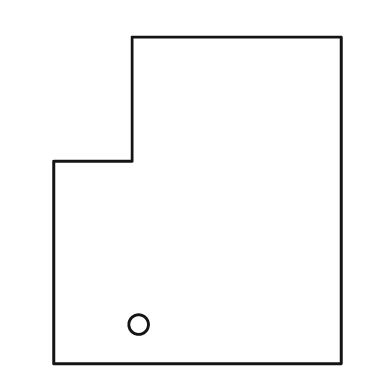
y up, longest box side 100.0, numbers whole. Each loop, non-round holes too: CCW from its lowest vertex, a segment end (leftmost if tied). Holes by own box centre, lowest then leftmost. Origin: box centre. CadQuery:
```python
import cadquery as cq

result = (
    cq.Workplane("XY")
    .moveTo(-44.0, -50.0)
    .lineTo(44.0, -50.0)
    .lineTo(44.0, 50.0)
    .lineTo(-20.0, 50.0)
    .lineTo(-20.0, 12.0)
    .lineTo(-44.0, 12.0)
    .close()
    .moveTo(-18.0, -38.0)
    .circle(3.0)
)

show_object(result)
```